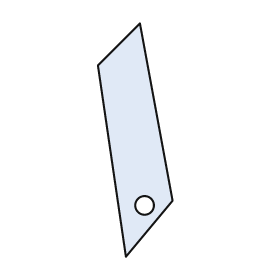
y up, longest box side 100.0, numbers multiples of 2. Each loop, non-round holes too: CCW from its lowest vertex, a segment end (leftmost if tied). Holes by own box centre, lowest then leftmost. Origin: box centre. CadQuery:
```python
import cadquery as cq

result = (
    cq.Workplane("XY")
    .moveTo(-4.0, -50.0)
    .lineTo(16.0, -26.0)
    .lineTo(2.0, 50.0)
    .lineTo(-16.0, 32.0)
    .close()
    .moveTo(4.0, -28.0)
    .circle(4.0)
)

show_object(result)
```